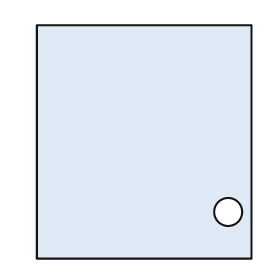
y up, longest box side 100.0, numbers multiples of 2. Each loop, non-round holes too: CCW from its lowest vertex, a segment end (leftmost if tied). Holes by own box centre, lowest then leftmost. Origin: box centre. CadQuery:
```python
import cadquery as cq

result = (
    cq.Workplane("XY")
    .moveTo(-46.0, -50.0)
    .lineTo(46.0, -50.0)
    .lineTo(46.0, 50.0)
    .lineTo(-46.0, 50.0)
    .close()
    .moveTo(36.0, -30.0)
    .circle(6.0)
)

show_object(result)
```